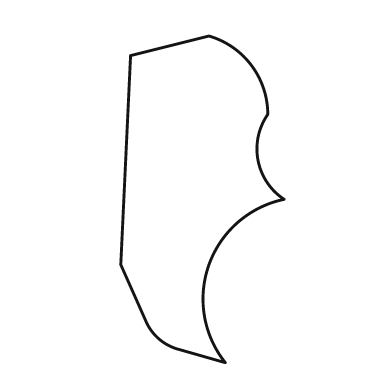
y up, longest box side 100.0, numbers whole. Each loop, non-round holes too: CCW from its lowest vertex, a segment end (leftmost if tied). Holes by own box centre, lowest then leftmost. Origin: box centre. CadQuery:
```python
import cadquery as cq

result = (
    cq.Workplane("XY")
    .moveTo(7.0, -50.0)
    .threePointArc((2.0, -20.0), (25.0, 0.0))
    .threePointArc((17.0, 12.0), (20.0, 26.0))
    .threePointArc((15.0, 41.0), (2.0, 50.0))
    .lineTo(-22.0, 44.0)
    .lineTo(-25.0, -20.0)
    .lineTo(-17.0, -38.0)
    .threePointArc((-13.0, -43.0), (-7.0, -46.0))
    .close()
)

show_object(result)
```